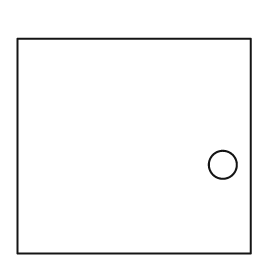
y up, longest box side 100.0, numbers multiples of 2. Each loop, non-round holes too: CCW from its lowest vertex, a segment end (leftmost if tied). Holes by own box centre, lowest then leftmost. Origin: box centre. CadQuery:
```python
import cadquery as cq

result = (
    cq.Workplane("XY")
    .moveTo(-50.0, -46.0)
    .lineTo(50.0, -46.0)
    .lineTo(50.0, 46.0)
    .lineTo(-50.0, 46.0)
    .close()
    .moveTo(38.0, -8.0)
    .circle(6.0)
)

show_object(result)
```